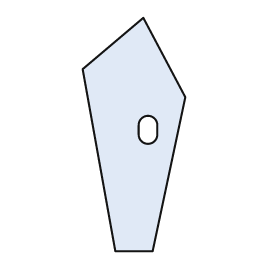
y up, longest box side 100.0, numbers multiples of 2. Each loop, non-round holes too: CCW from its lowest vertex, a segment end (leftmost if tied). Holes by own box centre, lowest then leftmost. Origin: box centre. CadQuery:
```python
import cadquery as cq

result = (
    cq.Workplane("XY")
    .moveTo(-8.0, -50.0)
    .lineTo(8.0, -50.0)
    .lineTo(22.0, 16.0)
    .lineTo(4.0, 50.0)
    .lineTo(-22.0, 28.0)
    .close()
    .moveTo(2.0, 0.0)
    .threePointArc((6.0, -4.0), (10.0, 0.0))
    .lineTo(10.0, 4.0)
    .threePointArc((6.0, 8.0), (2.0, 4.0))
    .close()
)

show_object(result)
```